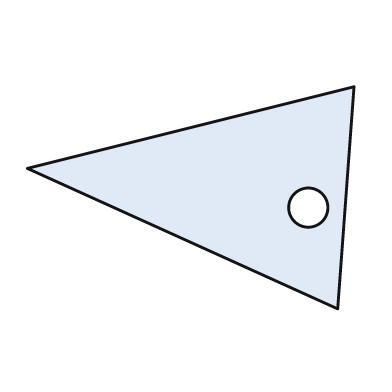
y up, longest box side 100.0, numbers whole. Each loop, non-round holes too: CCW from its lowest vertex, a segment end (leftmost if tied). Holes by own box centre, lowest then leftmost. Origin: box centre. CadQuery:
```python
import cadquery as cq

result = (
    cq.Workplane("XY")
    .moveTo(45.0, -34.0)
    .lineTo(50.0, 34.0)
    .lineTo(-50.0, 9.0)
    .close()
    .moveTo(36.0, -3.0)
    .circle(6.0)
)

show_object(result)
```